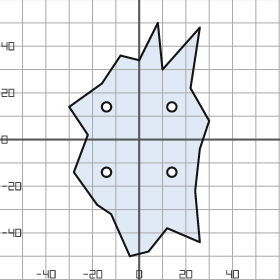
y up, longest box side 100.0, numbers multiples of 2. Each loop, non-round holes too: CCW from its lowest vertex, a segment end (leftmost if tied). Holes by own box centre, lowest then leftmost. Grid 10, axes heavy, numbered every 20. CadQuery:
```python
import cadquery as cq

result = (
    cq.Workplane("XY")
    .moveTo(-4.0, -50.0)
    .lineTo(4.0, -48.0)
    .lineTo(12.0, -38.0)
    .lineTo(26.0, -44.0)
    .lineTo(24.0, -22.0)
    .lineTo(26.0, -4.0)
    .lineTo(30.0, 8.0)
    .lineTo(22.0, 22.0)
    .lineTo(26.0, 48.0)
    .lineTo(10.0, 30.0)
    .lineTo(8.0, 50.0)
    .lineTo(0.0, 34.0)
    .lineTo(-8.0, 36.0)
    .lineTo(-16.0, 24.0)
    .lineTo(-30.0, 14.0)
    .lineTo(-22.0, 2.0)
    .lineTo(-28.0, -14.0)
    .lineTo(-18.0, -28.0)
    .lineTo(-12.0, -32.0)
    .close()
    .moveTo(-14.0, -14.0)
    .circle(2.0)
    .moveTo(14.0, -14.0)
    .circle(2.0)
    .moveTo(-14.0, 14.0)
    .circle(2.0)
    .moveTo(14.0, 14.0)
    .circle(2.0)
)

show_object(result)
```